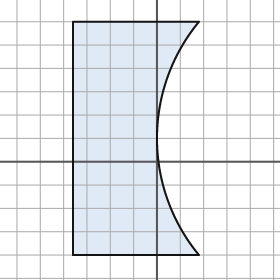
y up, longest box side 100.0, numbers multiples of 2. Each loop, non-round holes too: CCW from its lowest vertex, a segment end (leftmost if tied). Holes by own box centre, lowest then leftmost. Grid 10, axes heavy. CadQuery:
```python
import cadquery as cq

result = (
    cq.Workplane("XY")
    .moveTo(-36.0, -40.0)
    .lineTo(18.0, -40.0)
    .threePointArc((0.0, 10.0), (18.0, 60.0))
    .lineTo(-36.0, 60.0)
    .close()
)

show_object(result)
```